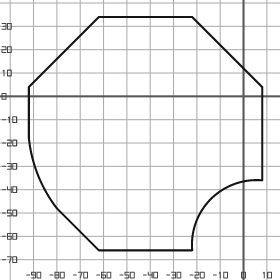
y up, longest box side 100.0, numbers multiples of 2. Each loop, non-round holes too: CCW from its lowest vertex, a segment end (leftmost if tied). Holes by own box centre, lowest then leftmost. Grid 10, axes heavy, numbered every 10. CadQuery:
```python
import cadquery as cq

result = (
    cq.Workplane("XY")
    .moveTo(-62.0, -66.0)
    .lineTo(-22.0, -66.0)
    .threePointArc((-14.0, -44.0), (8.0, -36.0))
    .lineTo(8.0, 4.0)
    .lineTo(-22.0, 34.0)
    .lineTo(-62.0, 34.0)
    .lineTo(-92.0, 4.0)
    .lineTo(-92.0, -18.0)
    .threePointArc((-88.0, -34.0), (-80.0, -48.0))
    .close()
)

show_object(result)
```